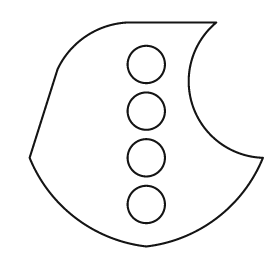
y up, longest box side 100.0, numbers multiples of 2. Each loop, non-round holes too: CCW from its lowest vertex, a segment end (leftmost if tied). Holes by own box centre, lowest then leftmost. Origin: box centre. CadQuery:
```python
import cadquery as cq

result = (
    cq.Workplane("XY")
    .moveTo(0.0, -48.0)
    .threePointArc((30.0, -36.0), (50.0, -10.0))
    .threePointArc((20.0, 12.0), (30.0, 48.0))
    .lineTo(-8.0, 48.0)
    .threePointArc((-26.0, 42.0), (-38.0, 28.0))
    .lineTo(-50.0, -10.0)
    .threePointArc((-30.0, -36.0), (0.0, -48.0))
    .close()
    .moveTo(0.0, -30.0)
    .circle(8.0)
    .moveTo(0.0, -10.0)
    .circle(8.0)
    .moveTo(0.0, 10.0)
    .circle(8.0)
    .moveTo(0.0, 30.0)
    .circle(8.0)
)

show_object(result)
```